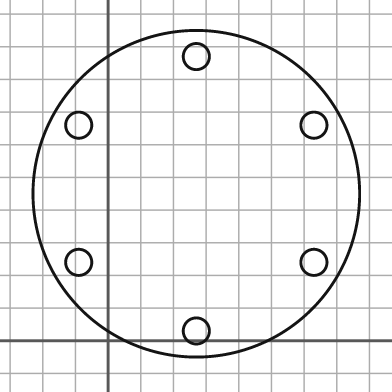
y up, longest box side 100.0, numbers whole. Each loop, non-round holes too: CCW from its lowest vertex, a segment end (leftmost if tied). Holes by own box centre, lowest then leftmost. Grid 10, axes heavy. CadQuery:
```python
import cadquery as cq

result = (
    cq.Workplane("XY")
    .moveTo(27.0, 45.0)
    .circle(50.0)
    .moveTo(27.0, 3.0)
    .circle(4.0)
    .moveTo(-9.0, 24.0)
    .circle(4.0)
    .moveTo(63.0, 24.0)
    .circle(4.0)
    .moveTo(-9.0, 66.0)
    .circle(4.0)
    .moveTo(63.0, 66.0)
    .circle(4.0)
    .moveTo(27.0, 87.0)
    .circle(4.0)
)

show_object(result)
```